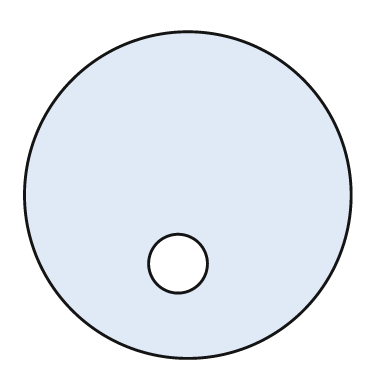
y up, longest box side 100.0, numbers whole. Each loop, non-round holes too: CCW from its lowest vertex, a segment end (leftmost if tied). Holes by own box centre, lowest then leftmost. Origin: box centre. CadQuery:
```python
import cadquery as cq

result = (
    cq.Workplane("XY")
    .moveTo(0.0, 0.0)
    .circle(50.0)
    .moveTo(-3.0, -21.0)
    .circle(9.0)
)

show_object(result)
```